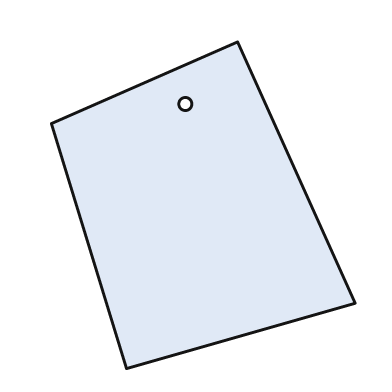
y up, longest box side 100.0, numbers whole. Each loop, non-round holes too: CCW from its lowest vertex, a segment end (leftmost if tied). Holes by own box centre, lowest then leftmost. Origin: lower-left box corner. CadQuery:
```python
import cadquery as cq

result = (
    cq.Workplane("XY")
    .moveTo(23.0, 0.0)
    .lineTo(93.0, 20.0)
    .lineTo(57.0, 100.0)
    .lineTo(0.0, 75.0)
    .close()
    .moveTo(41.0, 81.0)
    .circle(2.0)
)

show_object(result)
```